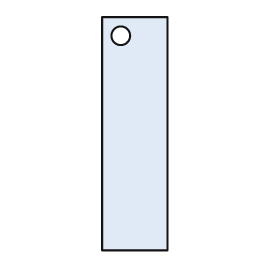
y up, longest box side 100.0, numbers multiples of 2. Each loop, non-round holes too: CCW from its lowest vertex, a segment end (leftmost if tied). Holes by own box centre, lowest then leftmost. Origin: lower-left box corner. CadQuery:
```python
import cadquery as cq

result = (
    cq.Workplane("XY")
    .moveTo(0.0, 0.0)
    .lineTo(28.0, 0.0)
    .lineTo(28.0, 100.0)
    .lineTo(0.0, 100.0)
    .close()
    .moveTo(8.0, 92.0)
    .circle(4.0)
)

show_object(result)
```